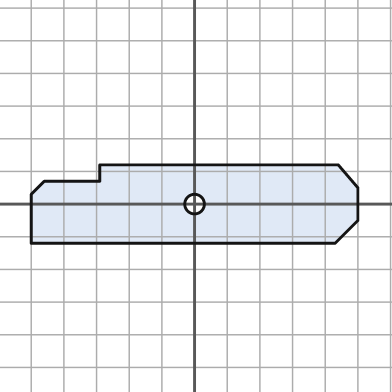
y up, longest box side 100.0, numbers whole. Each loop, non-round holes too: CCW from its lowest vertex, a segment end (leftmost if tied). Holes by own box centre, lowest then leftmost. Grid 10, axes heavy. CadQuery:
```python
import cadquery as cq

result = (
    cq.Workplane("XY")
    .moveTo(-50.0, -12.0)
    .lineTo(43.0, -12.0)
    .lineTo(50.0, -5.0)
    .lineTo(50.0, 5.0)
    .lineTo(44.0, 12.0)
    .lineTo(-29.0, 12.0)
    .lineTo(-29.0, 7.0)
    .lineTo(-46.0, 7.0)
    .lineTo(-50.0, 3.0)
    .close()
    .moveTo(0.0, 0.0)
    .circle(3.0)
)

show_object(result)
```